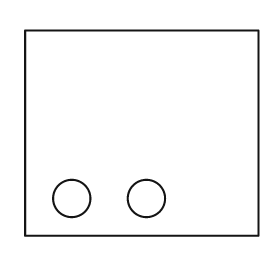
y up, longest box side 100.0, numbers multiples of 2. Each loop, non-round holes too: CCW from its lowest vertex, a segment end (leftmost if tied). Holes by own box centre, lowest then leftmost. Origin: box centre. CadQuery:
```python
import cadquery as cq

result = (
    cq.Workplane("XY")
    .moveTo(-50.0, -44.0)
    .lineTo(50.0, -44.0)
    .lineTo(50.0, 44.0)
    .lineTo(-50.0, 44.0)
    .close()
    .moveTo(-30.0, -28.0)
    .circle(8.0)
    .moveTo(2.0, -28.0)
    .circle(8.0)
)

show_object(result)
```